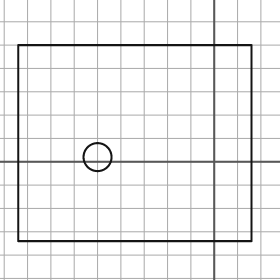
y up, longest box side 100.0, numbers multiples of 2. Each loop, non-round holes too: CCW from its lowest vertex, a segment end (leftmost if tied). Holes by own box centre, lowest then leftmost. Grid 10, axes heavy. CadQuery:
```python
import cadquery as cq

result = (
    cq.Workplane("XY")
    .moveTo(-84.0, -34.0)
    .lineTo(16.0, -34.0)
    .lineTo(16.0, 50.0)
    .lineTo(-84.0, 50.0)
    .close()
    .moveTo(-50.0, 2.0)
    .circle(6.0)
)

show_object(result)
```